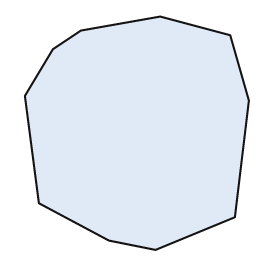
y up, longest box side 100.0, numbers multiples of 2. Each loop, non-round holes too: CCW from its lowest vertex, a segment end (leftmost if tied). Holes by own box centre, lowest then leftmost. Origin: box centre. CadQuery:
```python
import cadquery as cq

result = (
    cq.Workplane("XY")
    .moveTo(8.0, -50.0)
    .lineTo(42.0, -36.0)
    .lineTo(48.0, 14.0)
    .lineTo(40.0, 42.0)
    .lineTo(10.0, 50.0)
    .lineTo(-24.0, 44.0)
    .lineTo(-36.0, 36.0)
    .lineTo(-48.0, 16.0)
    .lineTo(-42.0, -30.0)
    .lineTo(-12.0, -46.0)
    .close()
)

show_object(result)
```